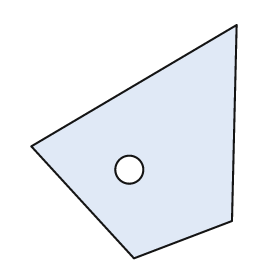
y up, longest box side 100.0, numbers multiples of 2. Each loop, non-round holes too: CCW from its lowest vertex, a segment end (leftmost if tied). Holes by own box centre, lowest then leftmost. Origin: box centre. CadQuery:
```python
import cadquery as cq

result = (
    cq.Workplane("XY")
    .moveTo(0.0, -50.0)
    .lineTo(42.0, -34.0)
    .lineTo(44.0, 50.0)
    .lineTo(-44.0, -2.0)
    .close()
    .moveTo(-2.0, -12.0)
    .circle(6.0)
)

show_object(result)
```